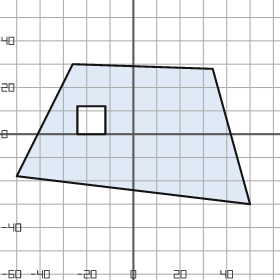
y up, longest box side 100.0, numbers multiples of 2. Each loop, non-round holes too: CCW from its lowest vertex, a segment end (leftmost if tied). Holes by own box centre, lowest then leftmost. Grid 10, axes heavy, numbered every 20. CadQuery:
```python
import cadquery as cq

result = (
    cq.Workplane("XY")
    .moveTo(50.0, -30.0)
    .lineTo(34.0, 28.0)
    .lineTo(-26.0, 30.0)
    .lineTo(-50.0, -18.0)
    .close()
    .moveTo(-24.0, 0.0)
    .lineTo(-12.0, 0.0)
    .lineTo(-12.0, 12.0)
    .lineTo(-24.0, 12.0)
    .close()
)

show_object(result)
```